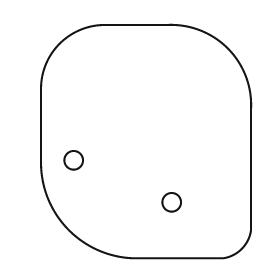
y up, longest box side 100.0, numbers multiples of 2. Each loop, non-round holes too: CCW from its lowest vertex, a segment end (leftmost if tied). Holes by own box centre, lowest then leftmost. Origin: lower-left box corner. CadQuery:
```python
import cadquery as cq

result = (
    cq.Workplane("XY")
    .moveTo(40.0, 0.0)
    .lineTo(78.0, 0.0)
    .threePointArc((86.0, 4.0), (90.0, 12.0))
    .lineTo(90.0, 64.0)
    .threePointArc((80.0, 90.0), (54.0, 100.0))
    .lineTo(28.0, 100.0)
    .threePointArc((8.0, 92.0), (0.0, 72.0))
    .lineTo(0.0, 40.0)
    .threePointArc((12.0, 12.0), (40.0, 0.0))
    .close()
    .moveTo(56.0, 24.0)
    .circle(4.0)
    .moveTo(14.0, 42.0)
    .circle(4.0)
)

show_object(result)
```